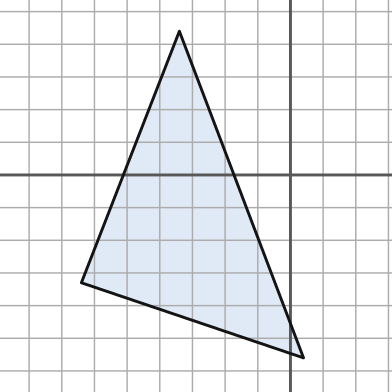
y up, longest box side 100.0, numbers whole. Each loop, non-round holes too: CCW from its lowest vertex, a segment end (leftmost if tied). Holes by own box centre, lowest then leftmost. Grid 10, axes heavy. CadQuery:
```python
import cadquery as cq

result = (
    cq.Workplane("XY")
    .moveTo(4.0, -56.0)
    .lineTo(-34.0, 44.0)
    .lineTo(-64.0, -33.0)
    .close()
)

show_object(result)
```